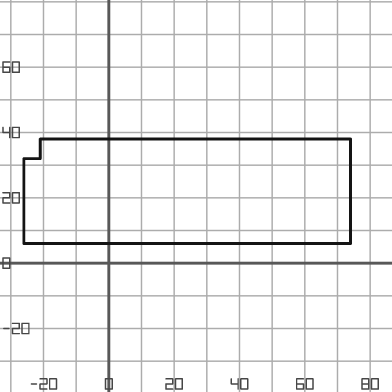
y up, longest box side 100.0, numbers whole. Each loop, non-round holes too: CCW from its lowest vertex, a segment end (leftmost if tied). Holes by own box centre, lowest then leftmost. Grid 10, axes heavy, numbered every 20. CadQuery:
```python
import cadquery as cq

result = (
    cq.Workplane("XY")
    .moveTo(-26.0, 6.0)
    .lineTo(74.0, 6.0)
    .lineTo(74.0, 38.0)
    .lineTo(-21.0, 38.0)
    .lineTo(-21.0, 32.0)
    .lineTo(-26.0, 32.0)
    .close()
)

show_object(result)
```